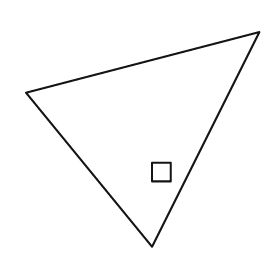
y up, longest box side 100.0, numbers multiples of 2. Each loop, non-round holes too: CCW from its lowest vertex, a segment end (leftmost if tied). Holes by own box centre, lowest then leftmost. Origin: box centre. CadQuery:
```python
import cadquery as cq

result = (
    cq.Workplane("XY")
    .moveTo(4.0, -46.0)
    .lineTo(50.0, 46.0)
    .lineTo(-50.0, 20.0)
    .close()
    .moveTo(4.0, -18.0)
    .lineTo(12.0, -18.0)
    .lineTo(12.0, -10.0)
    .lineTo(4.0, -10.0)
    .close()
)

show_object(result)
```